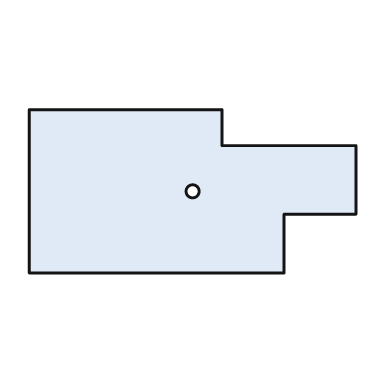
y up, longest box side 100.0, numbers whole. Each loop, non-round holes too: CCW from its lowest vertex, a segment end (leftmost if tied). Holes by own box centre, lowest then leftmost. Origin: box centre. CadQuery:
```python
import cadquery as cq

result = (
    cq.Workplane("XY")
    .moveTo(-50.0, -25.0)
    .lineTo(28.0, -25.0)
    .lineTo(28.0, -7.0)
    .lineTo(50.0, -7.0)
    .lineTo(50.0, 14.0)
    .lineTo(9.0, 14.0)
    .lineTo(9.0, 25.0)
    .lineTo(-50.0, 25.0)
    .close()
    .moveTo(0.0, 0.0)
    .circle(2.0)
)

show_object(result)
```